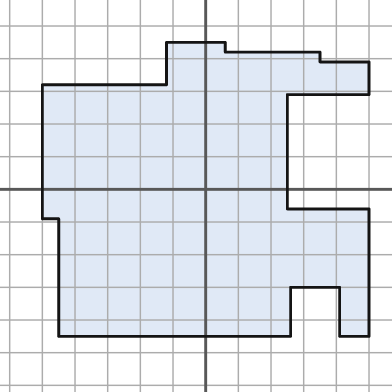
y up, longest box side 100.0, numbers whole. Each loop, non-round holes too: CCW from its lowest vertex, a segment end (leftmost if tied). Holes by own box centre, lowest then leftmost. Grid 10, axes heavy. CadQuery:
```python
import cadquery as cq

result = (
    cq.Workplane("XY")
    .moveTo(-45.0, -45.0)
    .lineTo(26.0, -45.0)
    .lineTo(26.0, -30.0)
    .lineTo(41.0, -30.0)
    .lineTo(41.0, -45.0)
    .lineTo(50.0, -45.0)
    .lineTo(50.0, -6.0)
    .lineTo(25.0, -6.0)
    .lineTo(25.0, 29.0)
    .lineTo(50.0, 29.0)
    .lineTo(50.0, 39.0)
    .lineTo(35.0, 39.0)
    .lineTo(35.0, 42.0)
    .lineTo(6.0, 42.0)
    .lineTo(6.0, 45.0)
    .lineTo(-12.0, 45.0)
    .lineTo(-12.0, 32.0)
    .lineTo(-50.0, 32.0)
    .lineTo(-50.0, -9.0)
    .lineTo(-45.0, -9.0)
    .close()
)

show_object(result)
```